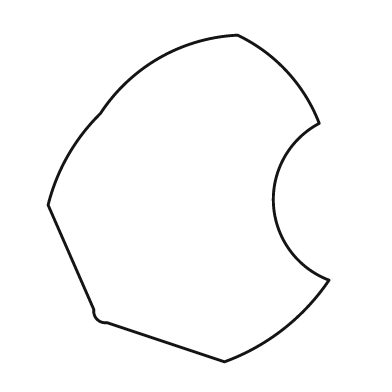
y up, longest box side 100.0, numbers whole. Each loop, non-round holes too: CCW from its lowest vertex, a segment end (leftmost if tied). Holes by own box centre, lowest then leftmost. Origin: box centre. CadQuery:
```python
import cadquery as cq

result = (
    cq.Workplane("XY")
    .moveTo(11.0, -50.0)
    .threePointArc((29.0, -40.0), (43.0, -25.0))
    .threePointArc((26.0, -2.0), (40.0, 23.0))
    .threePointArc((30.0, 39.0), (15.0, 50.0))
    .threePointArc((-9.0, 43.0), (-27.0, 26.0))
    .threePointArc((-37.0, 13.0), (-43.0, -2.0))
    .lineTo(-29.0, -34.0)
    .threePointArc((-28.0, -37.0), (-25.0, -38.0))
    .close()
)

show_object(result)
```